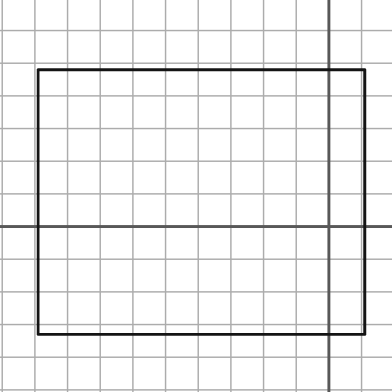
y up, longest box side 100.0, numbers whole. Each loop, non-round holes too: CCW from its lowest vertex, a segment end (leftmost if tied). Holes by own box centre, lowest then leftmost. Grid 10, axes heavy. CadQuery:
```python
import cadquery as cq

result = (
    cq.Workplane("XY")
    .moveTo(-89.0, -33.0)
    .lineTo(11.0, -33.0)
    .lineTo(11.0, 48.0)
    .lineTo(-89.0, 48.0)
    .close()
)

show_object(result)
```